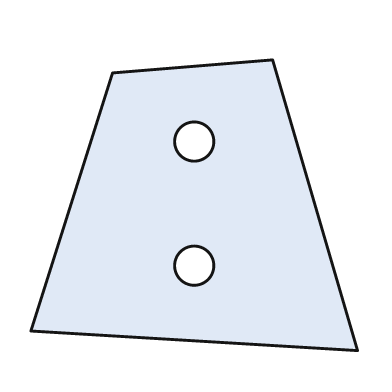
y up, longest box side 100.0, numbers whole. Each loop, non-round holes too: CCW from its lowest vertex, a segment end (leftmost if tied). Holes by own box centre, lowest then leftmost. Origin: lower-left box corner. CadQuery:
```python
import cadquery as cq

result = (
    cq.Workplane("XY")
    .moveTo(100.0, 0.0)
    .lineTo(74.0, 89.0)
    .lineTo(25.0, 85.0)
    .lineTo(0.0, 6.0)
    .close()
    .moveTo(50.0, 26.0)
    .circle(6.0)
    .moveTo(50.0, 64.0)
    .circle(6.0)
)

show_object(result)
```